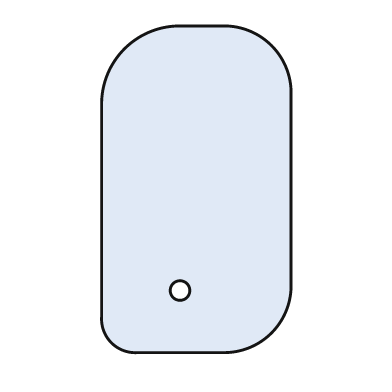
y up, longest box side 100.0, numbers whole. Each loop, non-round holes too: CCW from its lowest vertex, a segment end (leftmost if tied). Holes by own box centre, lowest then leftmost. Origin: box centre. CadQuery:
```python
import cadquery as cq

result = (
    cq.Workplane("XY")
    .moveTo(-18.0, -50.0)
    .lineTo(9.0, -50.0)
    .threePointArc((23.0, -44.0), (29.0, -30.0))
    .lineTo(29.0, 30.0)
    .threePointArc((23.0, 44.0), (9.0, 50.0))
    .lineTo(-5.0, 50.0)
    .threePointArc((-22.0, 43.0), (-29.0, 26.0))
    .lineTo(-29.0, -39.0)
    .threePointArc((-26.0, -47.0), (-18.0, -50.0))
    .close()
    .moveTo(-5.0, -31.0)
    .circle(3.0)
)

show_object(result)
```